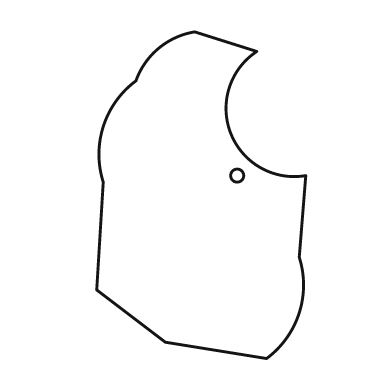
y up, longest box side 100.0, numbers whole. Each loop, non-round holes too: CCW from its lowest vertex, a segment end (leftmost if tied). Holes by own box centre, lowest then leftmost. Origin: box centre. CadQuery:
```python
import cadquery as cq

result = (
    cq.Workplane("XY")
    .moveTo(20.0, -50.0)
    .threePointArc((30.0, -36.0), (30.0, -19.0))
    .lineTo(32.0, 6.0)
    .threePointArc((9.0, 19.0), (17.0, 44.0))
    .lineTo(-2.0, 50.0)
    .threePointArc((-13.0, 45.0), (-20.0, 35.0))
    .threePointArc((-30.0, 21.0), (-30.0, 4.0))
    .lineTo(-32.0, -29.0)
    .lineTo(-11.0, -45.0)
    .close()
    .moveTo(11.0, 6.0)
    .circle(2.0)
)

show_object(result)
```